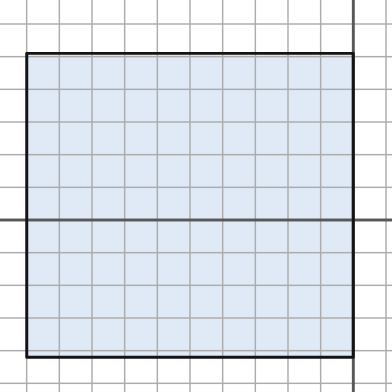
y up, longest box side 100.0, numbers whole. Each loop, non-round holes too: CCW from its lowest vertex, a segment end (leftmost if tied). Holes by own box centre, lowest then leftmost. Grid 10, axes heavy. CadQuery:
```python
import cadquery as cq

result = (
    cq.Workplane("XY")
    .moveTo(-100.0, -42.0)
    .lineTo(0.0, -42.0)
    .lineTo(0.0, 51.0)
    .lineTo(-100.0, 51.0)
    .close()
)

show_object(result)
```